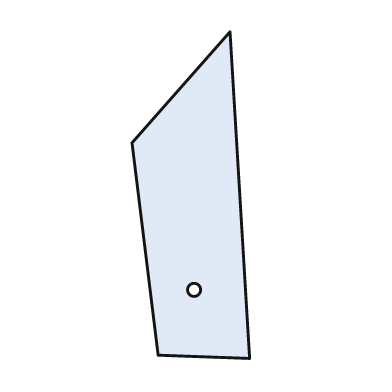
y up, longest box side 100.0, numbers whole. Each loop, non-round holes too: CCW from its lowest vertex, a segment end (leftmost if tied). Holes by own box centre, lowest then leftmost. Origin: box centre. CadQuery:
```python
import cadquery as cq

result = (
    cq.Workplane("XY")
    .moveTo(18.0, -50.0)
    .lineTo(12.0, 50.0)
    .lineTo(-18.0, 16.0)
    .lineTo(-10.0, -49.0)
    .close()
    .moveTo(1.0, -29.0)
    .circle(2.0)
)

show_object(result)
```